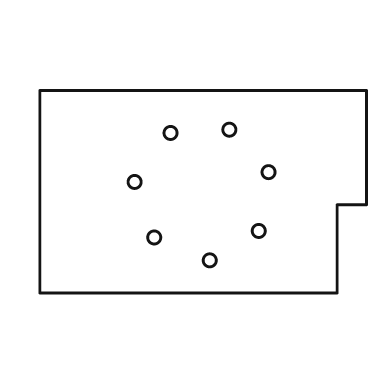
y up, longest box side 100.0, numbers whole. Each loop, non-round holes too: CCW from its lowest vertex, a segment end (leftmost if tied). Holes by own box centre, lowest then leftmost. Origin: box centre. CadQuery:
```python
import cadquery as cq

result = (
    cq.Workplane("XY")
    .moveTo(-50.0, -31.0)
    .lineTo(41.0, -31.0)
    .lineTo(41.0, -4.0)
    .lineTo(50.0, -4.0)
    .lineTo(50.0, 31.0)
    .lineTo(-50.0, 31.0)
    .close()
    .moveTo(2.0, -21.0)
    .circle(2.0)
    .moveTo(-15.0, -14.0)
    .circle(2.0)
    .moveTo(17.0, -12.0)
    .circle(2.0)
    .moveTo(-21.0, 3.0)
    .circle(2.0)
    .moveTo(20.0, 6.0)
    .circle(2.0)
    .moveTo(-10.0, 18.0)
    .circle(2.0)
    .moveTo(8.0, 19.0)
    .circle(2.0)
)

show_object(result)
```